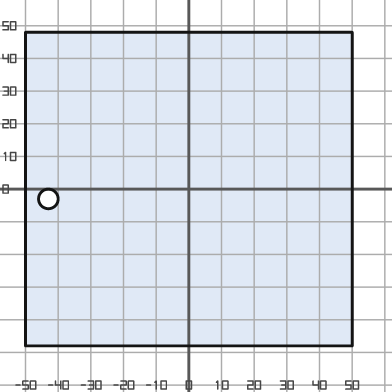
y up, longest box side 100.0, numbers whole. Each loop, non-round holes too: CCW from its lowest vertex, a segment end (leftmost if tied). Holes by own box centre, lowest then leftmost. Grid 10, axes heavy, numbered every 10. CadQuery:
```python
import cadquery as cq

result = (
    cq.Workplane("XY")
    .moveTo(-50.0, -48.0)
    .lineTo(50.0, -48.0)
    .lineTo(50.0, 48.0)
    .lineTo(-50.0, 48.0)
    .close()
    .moveTo(-43.0, -3.0)
    .circle(3.0)
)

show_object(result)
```